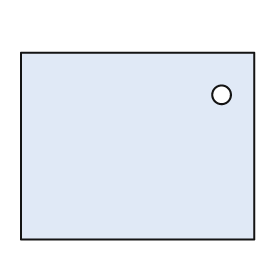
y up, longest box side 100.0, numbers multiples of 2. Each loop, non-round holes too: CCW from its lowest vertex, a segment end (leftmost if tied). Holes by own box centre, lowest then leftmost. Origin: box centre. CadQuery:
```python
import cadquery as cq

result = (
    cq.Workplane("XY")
    .moveTo(-50.0, -40.0)
    .lineTo(50.0, -40.0)
    .lineTo(50.0, 40.0)
    .lineTo(-50.0, 40.0)
    .close()
    .moveTo(36.0, 22.0)
    .circle(4.0)
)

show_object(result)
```